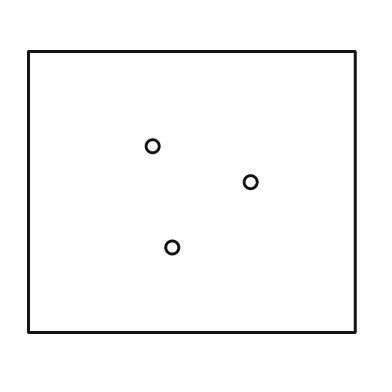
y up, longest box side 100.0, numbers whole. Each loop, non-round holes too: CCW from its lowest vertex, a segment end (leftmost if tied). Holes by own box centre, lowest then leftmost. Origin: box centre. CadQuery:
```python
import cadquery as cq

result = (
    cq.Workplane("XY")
    .moveTo(-50.0, -43.0)
    .lineTo(50.0, -43.0)
    .lineTo(50.0, 43.0)
    .lineTo(-50.0, 43.0)
    .close()
    .moveTo(-6.0, -17.0)
    .circle(2.0)
    .moveTo(18.0, 3.0)
    .circle(2.0)
    .moveTo(-12.0, 14.0)
    .circle(2.0)
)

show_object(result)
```